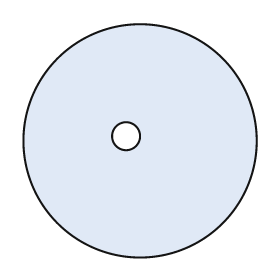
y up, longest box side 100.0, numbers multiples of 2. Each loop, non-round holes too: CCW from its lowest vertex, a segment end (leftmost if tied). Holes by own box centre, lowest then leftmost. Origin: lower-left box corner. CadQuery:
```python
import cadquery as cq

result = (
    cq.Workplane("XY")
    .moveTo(50.0, 50.0)
    .circle(50.0)
    .moveTo(44.0, 52.0)
    .circle(6.0)
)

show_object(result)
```